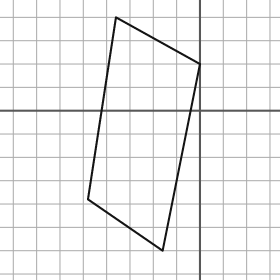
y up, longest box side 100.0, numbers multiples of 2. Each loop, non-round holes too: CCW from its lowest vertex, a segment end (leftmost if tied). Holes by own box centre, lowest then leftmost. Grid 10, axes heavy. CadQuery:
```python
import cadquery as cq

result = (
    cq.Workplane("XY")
    .moveTo(-16.0, -60.0)
    .lineTo(0.0, 20.0)
    .lineTo(-36.0, 40.0)
    .lineTo(-48.0, -38.0)
    .close()
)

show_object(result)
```